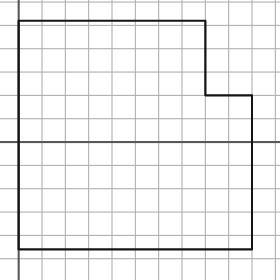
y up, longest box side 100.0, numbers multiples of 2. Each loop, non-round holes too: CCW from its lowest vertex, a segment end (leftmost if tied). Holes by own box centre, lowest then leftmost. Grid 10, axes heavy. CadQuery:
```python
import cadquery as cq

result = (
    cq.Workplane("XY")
    .moveTo(0.0, -46.0)
    .lineTo(100.0, -46.0)
    .lineTo(100.0, 20.0)
    .lineTo(80.0, 20.0)
    .lineTo(80.0, 52.0)
    .lineTo(0.0, 52.0)
    .close()
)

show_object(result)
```